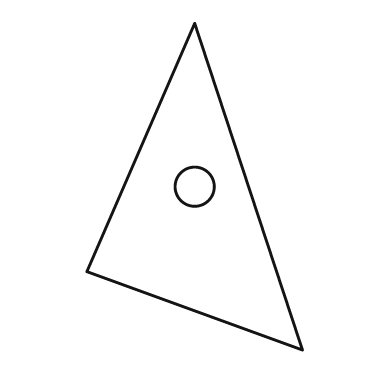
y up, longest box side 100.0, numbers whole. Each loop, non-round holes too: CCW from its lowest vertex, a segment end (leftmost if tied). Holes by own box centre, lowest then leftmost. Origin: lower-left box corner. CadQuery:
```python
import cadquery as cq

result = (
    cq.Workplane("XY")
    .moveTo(66.0, 0.0)
    .lineTo(33.0, 100.0)
    .lineTo(0.0, 24.0)
    .close()
    .moveTo(33.0, 50.0)
    .circle(6.0)
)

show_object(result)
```